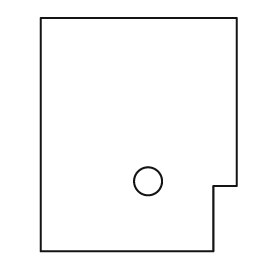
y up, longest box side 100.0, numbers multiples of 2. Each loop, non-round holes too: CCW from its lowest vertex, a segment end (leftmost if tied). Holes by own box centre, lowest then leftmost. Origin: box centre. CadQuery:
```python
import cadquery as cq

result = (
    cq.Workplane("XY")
    .moveTo(-42.0, -50.0)
    .lineTo(32.0, -50.0)
    .lineTo(32.0, -22.0)
    .lineTo(42.0, -22.0)
    .lineTo(42.0, 50.0)
    .lineTo(-42.0, 50.0)
    .close()
    .moveTo(4.0, -20.0)
    .circle(6.0)
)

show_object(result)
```